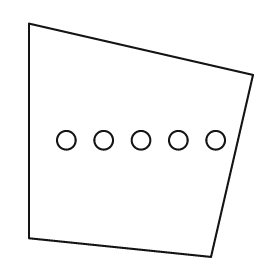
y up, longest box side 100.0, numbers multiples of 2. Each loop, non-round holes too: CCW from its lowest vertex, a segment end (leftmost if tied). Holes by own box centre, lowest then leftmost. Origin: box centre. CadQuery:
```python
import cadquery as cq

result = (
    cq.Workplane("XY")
    .moveTo(30.0, -50.0)
    .lineTo(48.0, 28.0)
    .lineTo(-48.0, 50.0)
    .lineTo(-48.0, -42.0)
    .close()
    .moveTo(-32.0, 0.0)
    .circle(4.0)
    .moveTo(-16.0, 0.0)
    .circle(4.0)
    .moveTo(0.0, 0.0)
    .circle(4.0)
    .moveTo(16.0, 0.0)
    .circle(4.0)
    .moveTo(32.0, 0.0)
    .circle(4.0)
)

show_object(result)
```